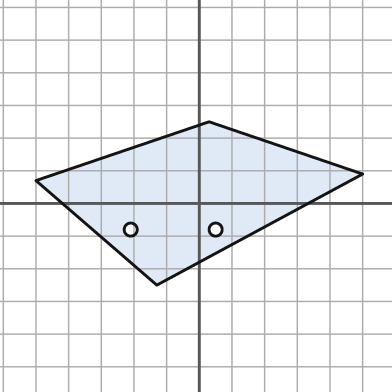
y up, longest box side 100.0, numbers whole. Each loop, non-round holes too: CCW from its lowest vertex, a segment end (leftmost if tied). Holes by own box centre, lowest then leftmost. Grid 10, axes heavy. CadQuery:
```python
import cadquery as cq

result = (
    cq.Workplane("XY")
    .moveTo(-13.0, -25.0)
    .lineTo(50.0, 9.0)
    .lineTo(3.0, 25.0)
    .lineTo(-50.0, 7.0)
    .close()
    .moveTo(-21.0, -8.0)
    .circle(2.0)
    .moveTo(5.0, -8.0)
    .circle(2.0)
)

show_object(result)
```